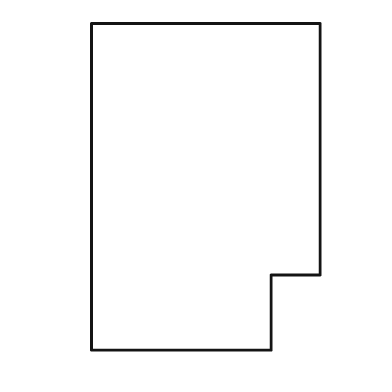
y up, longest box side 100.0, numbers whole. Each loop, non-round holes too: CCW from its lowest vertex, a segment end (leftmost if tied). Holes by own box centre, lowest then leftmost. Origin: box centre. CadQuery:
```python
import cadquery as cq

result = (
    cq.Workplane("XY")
    .moveTo(-35.0, -50.0)
    .lineTo(20.0, -50.0)
    .lineTo(20.0, -27.0)
    .lineTo(35.0, -27.0)
    .lineTo(35.0, 50.0)
    .lineTo(-35.0, 50.0)
    .close()
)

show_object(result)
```